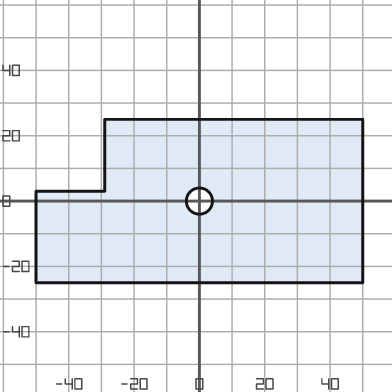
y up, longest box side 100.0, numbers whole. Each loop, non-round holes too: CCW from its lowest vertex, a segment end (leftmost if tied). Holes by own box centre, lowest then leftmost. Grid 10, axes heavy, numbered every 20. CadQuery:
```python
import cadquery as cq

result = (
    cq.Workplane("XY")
    .moveTo(-50.0, -25.0)
    .lineTo(50.0, -25.0)
    .lineTo(50.0, 25.0)
    .lineTo(-29.0, 25.0)
    .lineTo(-29.0, 3.0)
    .lineTo(-50.0, 3.0)
    .close()
    .moveTo(0.0, 0.0)
    .circle(4.0)
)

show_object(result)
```